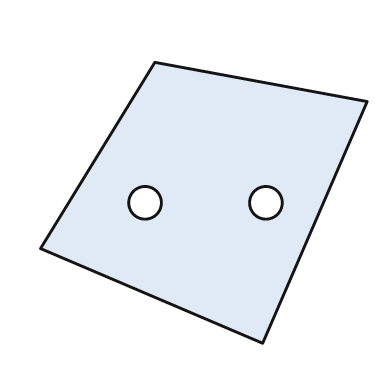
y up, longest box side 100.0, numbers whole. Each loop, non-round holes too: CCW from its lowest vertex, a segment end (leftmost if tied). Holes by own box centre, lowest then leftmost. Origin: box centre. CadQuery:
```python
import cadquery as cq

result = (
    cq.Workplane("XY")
    .moveTo(18.0, -43.0)
    .lineTo(50.0, 31.0)
    .lineTo(-15.0, 43.0)
    .lineTo(-50.0, -14.0)
    .close()
    .moveTo(-18.0, 0.0)
    .circle(5.0)
    .moveTo(19.0, 0.0)
    .circle(5.0)
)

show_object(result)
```